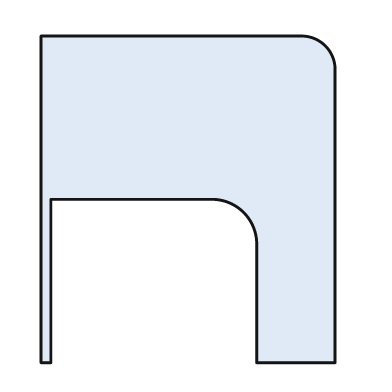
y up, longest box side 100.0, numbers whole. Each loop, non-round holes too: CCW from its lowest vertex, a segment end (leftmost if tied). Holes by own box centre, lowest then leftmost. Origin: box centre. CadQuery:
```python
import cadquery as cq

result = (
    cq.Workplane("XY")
    .moveTo(-45.0, -50.0)
    .lineTo(-42.0, -50.0)
    .lineTo(-42.0, 0.0)
    .lineTo(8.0, 0.0)
    .threePointArc((17.0, -4.0), (21.0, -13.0))
    .lineTo(21.0, -50.0)
    .lineTo(45.0, -50.0)
    .lineTo(45.0, 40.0)
    .threePointArc((42.0, 47.0), (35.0, 50.0))
    .lineTo(-45.0, 50.0)
    .close()
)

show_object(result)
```